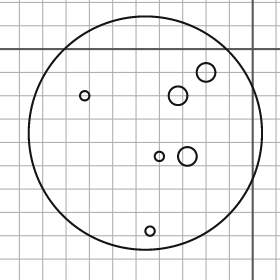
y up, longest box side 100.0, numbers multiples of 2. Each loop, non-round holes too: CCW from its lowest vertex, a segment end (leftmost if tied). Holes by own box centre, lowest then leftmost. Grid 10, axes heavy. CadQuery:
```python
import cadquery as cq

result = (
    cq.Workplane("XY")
    .moveTo(-46.0, -36.0)
    .circle(50.0)
    .moveTo(-44.0, -78.0)
    .circle(2.0)
    .moveTo(-40.0, -46.0)
    .circle(2.0)
    .moveTo(-28.0, -46.0)
    .circle(4.0)
    .moveTo(-72.0, -20.0)
    .circle(2.0)
    .moveTo(-32.0, -20.0)
    .circle(4.0)
    .moveTo(-20.0, -10.0)
    .circle(4.0)
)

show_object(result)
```